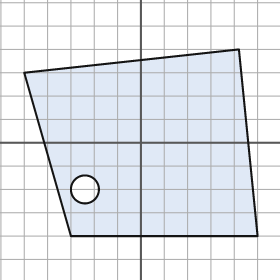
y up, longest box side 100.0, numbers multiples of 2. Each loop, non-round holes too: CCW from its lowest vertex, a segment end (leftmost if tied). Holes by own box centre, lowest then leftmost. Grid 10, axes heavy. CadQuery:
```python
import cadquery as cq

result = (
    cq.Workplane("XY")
    .moveTo(-30.0, -40.0)
    .lineTo(50.0, -40.0)
    .lineTo(42.0, 40.0)
    .lineTo(-50.0, 30.0)
    .close()
    .moveTo(-24.0, -20.0)
    .circle(6.0)
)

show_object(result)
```